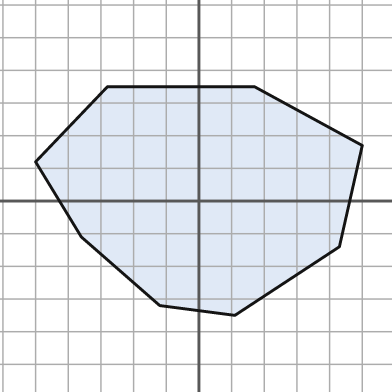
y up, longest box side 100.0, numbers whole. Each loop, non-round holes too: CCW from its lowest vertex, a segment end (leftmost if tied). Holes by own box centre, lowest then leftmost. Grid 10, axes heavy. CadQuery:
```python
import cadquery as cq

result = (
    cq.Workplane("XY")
    .moveTo(11.0, -35.0)
    .lineTo(43.0, -14.0)
    .lineTo(50.0, 17.0)
    .lineTo(17.0, 35.0)
    .lineTo(-28.0, 35.0)
    .lineTo(-50.0, 12.0)
    .lineTo(-36.0, -11.0)
    .lineTo(-12.0, -32.0)
    .close()
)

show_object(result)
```